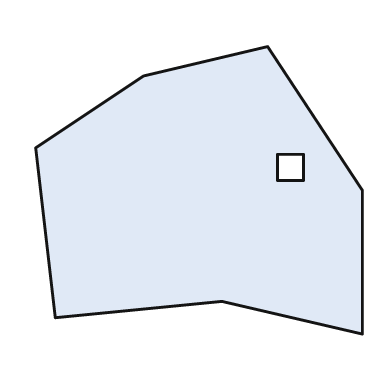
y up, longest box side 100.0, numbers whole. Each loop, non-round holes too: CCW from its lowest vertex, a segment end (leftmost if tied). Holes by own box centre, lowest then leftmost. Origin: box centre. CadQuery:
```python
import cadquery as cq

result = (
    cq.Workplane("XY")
    .moveTo(50.0, -44.0)
    .lineTo(50.0, 0.0)
    .lineTo(21.0, 44.0)
    .lineTo(-17.0, 35.0)
    .lineTo(-50.0, 13.0)
    .lineTo(-44.0, -39.0)
    .lineTo(7.0, -34.0)
    .close()
    .moveTo(24.0, 3.0)
    .lineTo(32.0, 3.0)
    .lineTo(32.0, 11.0)
    .lineTo(24.0, 11.0)
    .close()
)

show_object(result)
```